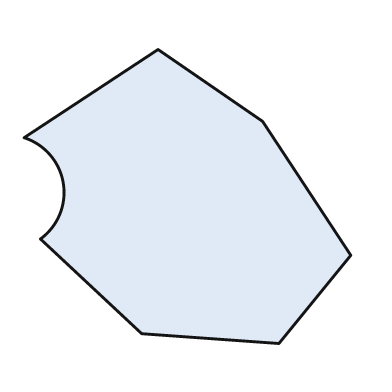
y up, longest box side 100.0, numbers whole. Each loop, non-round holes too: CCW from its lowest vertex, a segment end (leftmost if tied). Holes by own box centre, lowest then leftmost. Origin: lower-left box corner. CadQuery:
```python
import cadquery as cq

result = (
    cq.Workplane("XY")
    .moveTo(78.0, 0.0)
    .lineTo(100.0, 27.0)
    .lineTo(73.0, 68.0)
    .lineTo(41.0, 90.0)
    .lineTo(0.0, 63.0)
    .threePointArc((12.0, 49.0), (5.0, 32.0))
    .lineTo(36.0, 3.0)
    .close()
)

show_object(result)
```